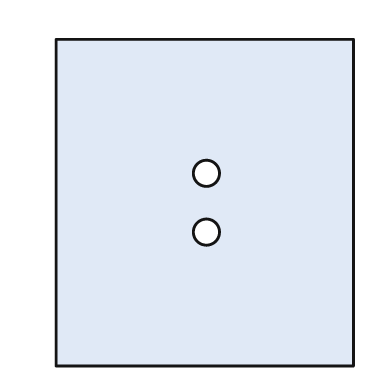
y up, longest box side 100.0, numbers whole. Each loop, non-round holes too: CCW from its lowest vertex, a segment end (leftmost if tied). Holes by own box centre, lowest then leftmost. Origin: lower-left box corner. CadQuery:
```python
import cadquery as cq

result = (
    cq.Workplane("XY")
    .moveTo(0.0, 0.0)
    .lineTo(91.0, 0.0)
    .lineTo(91.0, 100.0)
    .lineTo(0.0, 100.0)
    .close()
    .moveTo(46.0, 41.0)
    .circle(4.0)
    .moveTo(46.0, 59.0)
    .circle(4.0)
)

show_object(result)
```